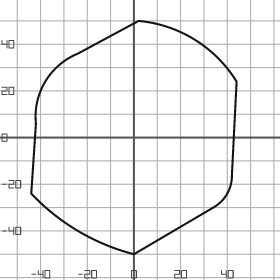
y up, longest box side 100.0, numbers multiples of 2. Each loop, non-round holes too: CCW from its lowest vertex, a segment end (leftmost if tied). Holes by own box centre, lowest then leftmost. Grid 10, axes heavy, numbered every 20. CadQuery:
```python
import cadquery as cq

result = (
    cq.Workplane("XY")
    .moveTo(0.0, -50.0)
    .lineTo(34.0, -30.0)
    .threePointArc((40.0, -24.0), (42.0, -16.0))
    .lineTo(44.0, 24.0)
    .threePointArc((26.0, 42.0), (2.0, 50.0))
    .lineTo(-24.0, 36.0)
    .threePointArc((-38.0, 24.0), (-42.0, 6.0))
    .lineTo(-44.0, -24.0)
    .threePointArc((-24.0, -40.0), (0.0, -50.0))
    .close()
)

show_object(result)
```